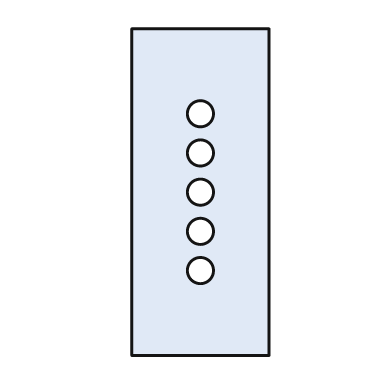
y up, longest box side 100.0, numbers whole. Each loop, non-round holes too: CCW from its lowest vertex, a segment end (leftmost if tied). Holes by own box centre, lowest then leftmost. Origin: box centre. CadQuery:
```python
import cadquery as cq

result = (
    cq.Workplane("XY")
    .moveTo(-21.0, -50.0)
    .lineTo(21.0, -50.0)
    .lineTo(21.0, 50.0)
    .lineTo(-21.0, 50.0)
    .close()
    .moveTo(0.0, -24.0)
    .circle(4.0)
    .moveTo(0.0, -12.0)
    .circle(4.0)
    .moveTo(0.0, 0.0)
    .circle(4.0)
    .moveTo(0.0, 12.0)
    .circle(4.0)
    .moveTo(0.0, 24.0)
    .circle(4.0)
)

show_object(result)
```